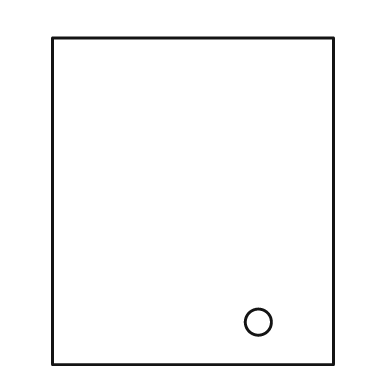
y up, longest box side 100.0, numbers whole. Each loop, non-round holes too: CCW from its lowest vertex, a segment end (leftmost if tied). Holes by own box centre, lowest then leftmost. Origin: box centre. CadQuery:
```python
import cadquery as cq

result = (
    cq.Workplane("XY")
    .moveTo(-43.0, -50.0)
    .lineTo(43.0, -50.0)
    .lineTo(43.0, 50.0)
    .lineTo(-43.0, 50.0)
    .close()
    .moveTo(20.0, -37.0)
    .circle(4.0)
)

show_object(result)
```